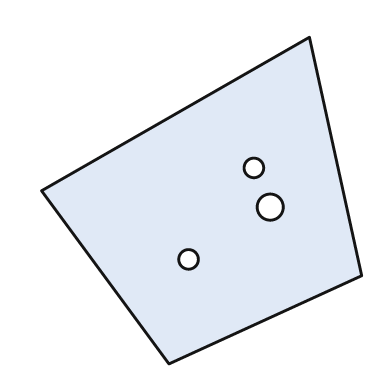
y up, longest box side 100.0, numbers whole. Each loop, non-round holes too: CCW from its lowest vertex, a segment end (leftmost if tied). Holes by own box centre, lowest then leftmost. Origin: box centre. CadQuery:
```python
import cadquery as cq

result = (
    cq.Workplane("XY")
    .moveTo(-10.0, -50.0)
    .lineTo(49.0, -23.0)
    .lineTo(33.0, 50.0)
    .lineTo(-49.0, 3.0)
    .close()
    .moveTo(-4.0, -18.0)
    .circle(3.0)
    .moveTo(21.0, -2.0)
    .circle(4.0)
    .moveTo(16.0, 10.0)
    .circle(3.0)
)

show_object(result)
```